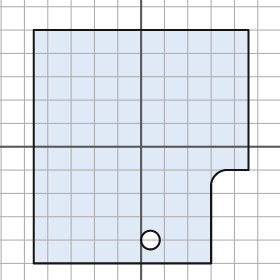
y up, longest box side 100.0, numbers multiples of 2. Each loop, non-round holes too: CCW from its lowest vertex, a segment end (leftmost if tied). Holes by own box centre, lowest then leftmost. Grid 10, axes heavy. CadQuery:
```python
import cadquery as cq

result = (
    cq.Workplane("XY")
    .moveTo(-46.0, -50.0)
    .lineTo(30.0, -50.0)
    .lineTo(30.0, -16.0)
    .threePointArc((32.0, -12.0), (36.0, -10.0))
    .lineTo(46.0, -10.0)
    .lineTo(46.0, 50.0)
    .lineTo(-46.0, 50.0)
    .close()
    .moveTo(4.0, -40.0)
    .circle(4.0)
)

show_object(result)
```